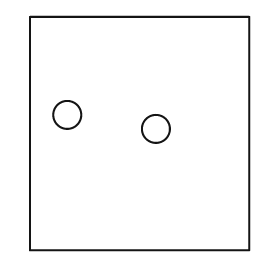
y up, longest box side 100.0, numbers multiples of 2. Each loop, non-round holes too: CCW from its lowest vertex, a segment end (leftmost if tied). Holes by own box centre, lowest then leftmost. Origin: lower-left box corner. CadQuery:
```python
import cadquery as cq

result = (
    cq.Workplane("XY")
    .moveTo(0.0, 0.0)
    .lineTo(94.0, 0.0)
    .lineTo(94.0, 100.0)
    .lineTo(0.0, 100.0)
    .close()
    .moveTo(54.0, 52.0)
    .circle(6.0)
    .moveTo(16.0, 58.0)
    .circle(6.0)
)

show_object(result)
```